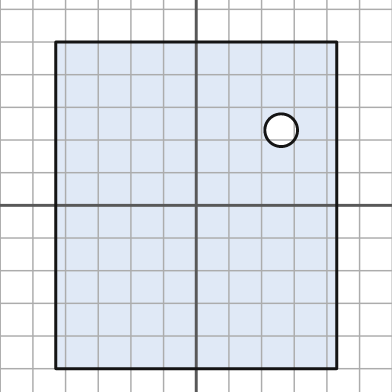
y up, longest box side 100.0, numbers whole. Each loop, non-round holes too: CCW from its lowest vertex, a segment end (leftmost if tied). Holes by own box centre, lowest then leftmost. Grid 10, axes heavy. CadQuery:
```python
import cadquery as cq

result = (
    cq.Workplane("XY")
    .moveTo(-43.0, -50.0)
    .lineTo(43.0, -50.0)
    .lineTo(43.0, 50.0)
    .lineTo(-43.0, 50.0)
    .close()
    .moveTo(26.0, 23.0)
    .circle(5.0)
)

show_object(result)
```